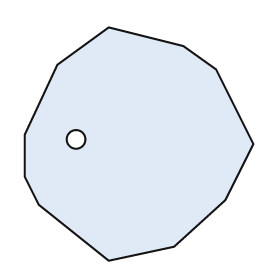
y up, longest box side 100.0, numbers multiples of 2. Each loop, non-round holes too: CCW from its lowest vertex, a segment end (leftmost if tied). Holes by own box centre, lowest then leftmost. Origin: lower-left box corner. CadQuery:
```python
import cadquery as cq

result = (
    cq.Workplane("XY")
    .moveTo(36.0, 0.0)
    .lineTo(64.0, 6.0)
    .lineTo(86.0, 26.0)
    .lineTo(98.0, 50.0)
    .lineTo(82.0, 82.0)
    .lineTo(68.0, 92.0)
    .lineTo(36.0, 100.0)
    .lineTo(14.0, 84.0)
    .lineTo(0.0, 54.0)
    .lineTo(0.0, 36.0)
    .lineTo(6.0, 24.0)
    .close()
    .moveTo(22.0, 52.0)
    .circle(4.0)
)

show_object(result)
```